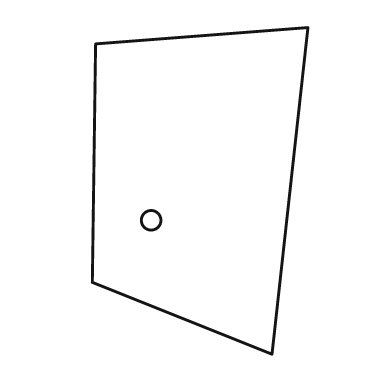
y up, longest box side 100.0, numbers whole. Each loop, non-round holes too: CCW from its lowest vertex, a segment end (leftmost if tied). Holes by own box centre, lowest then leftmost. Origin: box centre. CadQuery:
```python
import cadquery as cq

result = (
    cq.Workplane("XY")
    .moveTo(22.0, -50.0)
    .lineTo(33.0, 50.0)
    .lineTo(-32.0, 45.0)
    .lineTo(-33.0, -28.0)
    .close()
    .moveTo(-15.0, -9.0)
    .circle(3.0)
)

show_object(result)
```